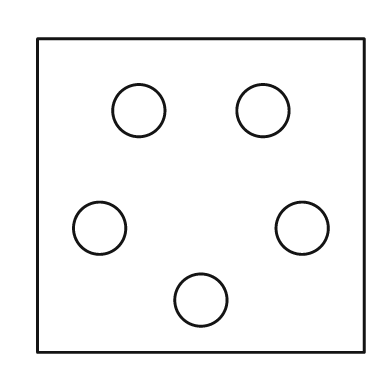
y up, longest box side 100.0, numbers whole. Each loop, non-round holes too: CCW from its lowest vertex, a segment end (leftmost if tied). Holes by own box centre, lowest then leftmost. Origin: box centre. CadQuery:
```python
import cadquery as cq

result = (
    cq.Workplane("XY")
    .moveTo(-50.0, -48.0)
    .lineTo(50.0, -48.0)
    .lineTo(50.0, 48.0)
    .lineTo(-50.0, 48.0)
    .close()
    .moveTo(0.0, -32.0)
    .circle(8.0)
    .moveTo(-31.0, -10.0)
    .circle(8.0)
    .moveTo(31.0, -10.0)
    .circle(8.0)
    .moveTo(-19.0, 26.0)
    .circle(8.0)
    .moveTo(19.0, 26.0)
    .circle(8.0)
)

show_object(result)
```